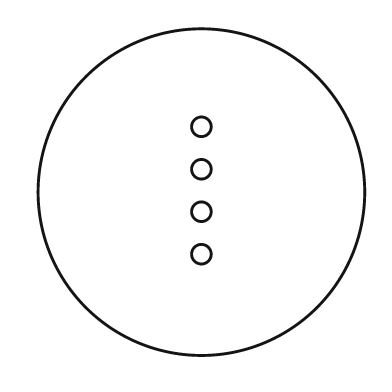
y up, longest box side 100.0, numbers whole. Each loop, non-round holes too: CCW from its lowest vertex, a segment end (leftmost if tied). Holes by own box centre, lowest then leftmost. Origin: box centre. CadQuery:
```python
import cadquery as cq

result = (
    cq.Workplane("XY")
    .moveTo(0.0, 0.0)
    .circle(50.0)
    .moveTo(0.0, -19.0)
    .circle(3.0)
    .moveTo(0.0, -6.0)
    .circle(3.0)
    .moveTo(0.0, 7.0)
    .circle(3.0)
    .moveTo(0.0, 20.0)
    .circle(3.0)
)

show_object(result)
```